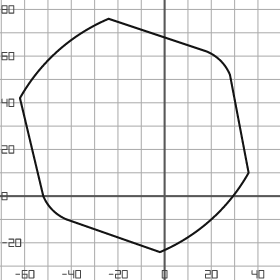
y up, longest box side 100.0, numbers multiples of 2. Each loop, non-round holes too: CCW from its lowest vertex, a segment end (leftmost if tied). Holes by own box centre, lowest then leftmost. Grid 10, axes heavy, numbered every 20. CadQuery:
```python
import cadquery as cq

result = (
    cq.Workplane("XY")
    .moveTo(-2.0, -24.0)
    .threePointArc((20.0, -10.0), (36.0, 10.0))
    .lineTo(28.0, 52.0)
    .threePointArc((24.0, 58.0), (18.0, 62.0))
    .lineTo(-24.0, 76.0)
    .threePointArc((-46.0, 62.0), (-62.0, 42.0))
    .lineTo(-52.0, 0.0)
    .threePointArc((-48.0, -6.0), (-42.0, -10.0))
    .close()
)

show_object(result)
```